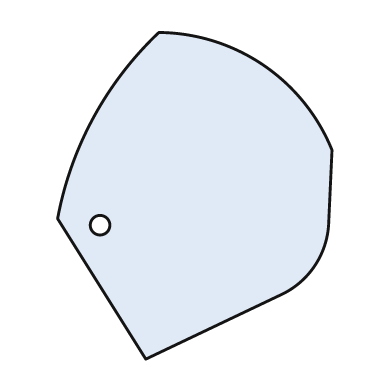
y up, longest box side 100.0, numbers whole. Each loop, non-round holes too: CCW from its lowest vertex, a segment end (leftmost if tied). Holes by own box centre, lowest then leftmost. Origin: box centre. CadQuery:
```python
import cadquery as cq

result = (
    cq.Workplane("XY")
    .moveTo(-15.0, -50.0)
    .lineTo(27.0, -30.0)
    .threePointArc((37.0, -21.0), (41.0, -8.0))
    .lineTo(42.0, 14.0)
    .threePointArc((21.0, 40.0), (-11.0, 50.0))
    .threePointArc((-31.0, 24.0), (-42.0, -7.0))
    .close()
    .moveTo(-29.0, -9.0)
    .circle(3.0)
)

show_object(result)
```